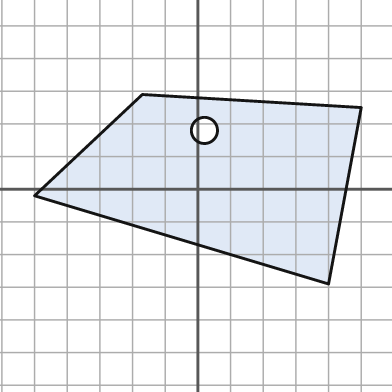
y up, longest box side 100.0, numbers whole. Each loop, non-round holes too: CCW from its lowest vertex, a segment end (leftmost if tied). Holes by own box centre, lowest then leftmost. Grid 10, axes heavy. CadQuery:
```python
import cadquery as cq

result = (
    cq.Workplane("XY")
    .moveTo(40.0, -29.0)
    .lineTo(50.0, 25.0)
    .lineTo(-17.0, 29.0)
    .lineTo(-50.0, -2.0)
    .close()
    .moveTo(2.0, 18.0)
    .circle(4.0)
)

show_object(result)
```